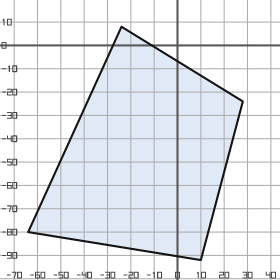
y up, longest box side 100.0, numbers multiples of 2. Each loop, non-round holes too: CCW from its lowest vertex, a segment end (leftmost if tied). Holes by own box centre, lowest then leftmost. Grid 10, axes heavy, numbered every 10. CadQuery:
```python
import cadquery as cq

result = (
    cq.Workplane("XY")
    .moveTo(10.0, -92.0)
    .lineTo(28.0, -24.0)
    .lineTo(-24.0, 8.0)
    .lineTo(-64.0, -80.0)
    .close()
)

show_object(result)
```